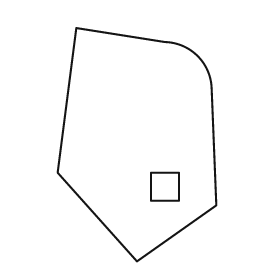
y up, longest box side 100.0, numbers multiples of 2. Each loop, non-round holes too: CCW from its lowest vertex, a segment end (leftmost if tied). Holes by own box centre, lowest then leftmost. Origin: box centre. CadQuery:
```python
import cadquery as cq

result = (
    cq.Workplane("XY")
    .moveTo(0.0, -50.0)
    .lineTo(34.0, -26.0)
    .lineTo(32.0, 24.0)
    .threePointArc((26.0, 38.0), (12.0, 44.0))
    .lineTo(-26.0, 50.0)
    .lineTo(-34.0, -12.0)
    .close()
    .moveTo(6.0, -24.0)
    .lineTo(18.0, -24.0)
    .lineTo(18.0, -12.0)
    .lineTo(6.0, -12.0)
    .close()
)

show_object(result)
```